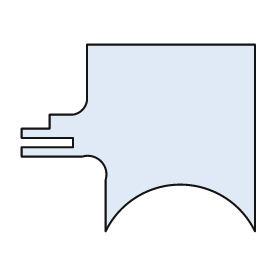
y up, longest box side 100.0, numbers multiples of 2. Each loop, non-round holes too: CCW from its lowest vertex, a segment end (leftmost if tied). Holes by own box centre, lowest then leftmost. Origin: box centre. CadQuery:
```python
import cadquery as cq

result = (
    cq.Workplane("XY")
    .moveTo(-14.0, -40.0)
    .threePointArc((18.0, -20.0), (50.0, -40.0))
    .lineTo(50.0, 40.0)
    .lineTo(-22.0, 40.0)
    .lineTo(-22.0, 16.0)
    .threePointArc((-24.0, 12.0), (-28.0, 10.0))
    .lineTo(-38.0, 10.0)
    .lineTo(-38.0, 4.0)
    .lineTo(-50.0, 4.0)
    .lineTo(-50.0, 0.0)
    .lineTo(-28.0, 0.0)
    .lineTo(-28.0, -4.0)
    .lineTo(-50.0, -4.0)
    .lineTo(-50.0, -8.0)
    .lineTo(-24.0, -8.0)
    .threePointArc((-16.0, -10.0), (-14.0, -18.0))
    .close()
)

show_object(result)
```